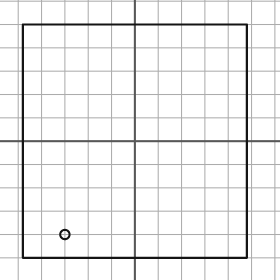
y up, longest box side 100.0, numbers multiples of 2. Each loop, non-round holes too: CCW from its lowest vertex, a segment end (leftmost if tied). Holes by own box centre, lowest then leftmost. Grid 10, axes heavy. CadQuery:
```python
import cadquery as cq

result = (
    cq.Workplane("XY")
    .moveTo(-48.0, -50.0)
    .lineTo(48.0, -50.0)
    .lineTo(48.0, 50.0)
    .lineTo(-48.0, 50.0)
    .close()
    .moveTo(-30.0, -40.0)
    .circle(2.0)
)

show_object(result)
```